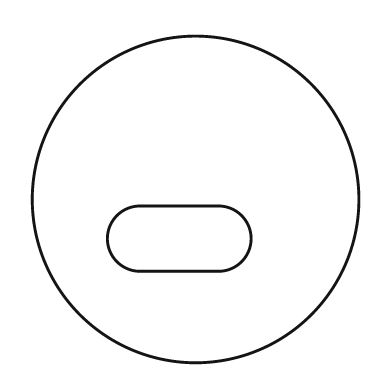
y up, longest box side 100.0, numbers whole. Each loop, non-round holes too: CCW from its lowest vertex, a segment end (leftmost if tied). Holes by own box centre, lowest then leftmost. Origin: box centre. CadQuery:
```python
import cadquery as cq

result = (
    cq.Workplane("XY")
    .moveTo(0.0, 0.0)
    .circle(50.0)
    .moveTo(-17.0, -22.0)
    .lineTo(7.0, -22.0)
    .threePointArc((17.0, -12.0), (7.0, -2.0))
    .lineTo(-17.0, -2.0)
    .threePointArc((-27.0, -12.0), (-17.0, -22.0))
    .close()
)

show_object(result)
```